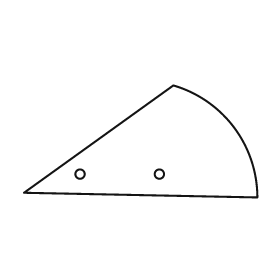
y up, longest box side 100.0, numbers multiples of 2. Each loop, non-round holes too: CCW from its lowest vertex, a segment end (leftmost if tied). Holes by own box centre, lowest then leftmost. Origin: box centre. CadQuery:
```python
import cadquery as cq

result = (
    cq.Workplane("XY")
    .moveTo(50.0, -24.0)
    .threePointArc((40.0, 6.0), (14.0, 24.0))
    .lineTo(-50.0, -22.0)
    .close()
    .moveTo(-26.0, -14.0)
    .circle(2.0)
    .moveTo(8.0, -14.0)
    .circle(2.0)
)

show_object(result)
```